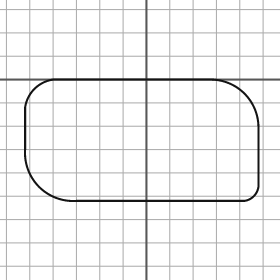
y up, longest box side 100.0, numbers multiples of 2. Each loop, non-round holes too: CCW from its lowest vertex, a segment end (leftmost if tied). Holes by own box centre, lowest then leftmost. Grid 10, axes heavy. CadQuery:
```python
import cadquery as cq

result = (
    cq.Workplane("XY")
    .moveTo(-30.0, -52.0)
    .lineTo(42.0, -52.0)
    .threePointArc((46.0, -50.0), (48.0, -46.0))
    .lineTo(48.0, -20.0)
    .threePointArc((42.0, -6.0), (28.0, 0.0))
    .lineTo(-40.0, 0.0)
    .threePointArc((-48.0, -4.0), (-52.0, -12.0))
    .lineTo(-52.0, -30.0)
    .threePointArc((-46.0, -46.0), (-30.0, -52.0))
    .close()
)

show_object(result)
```